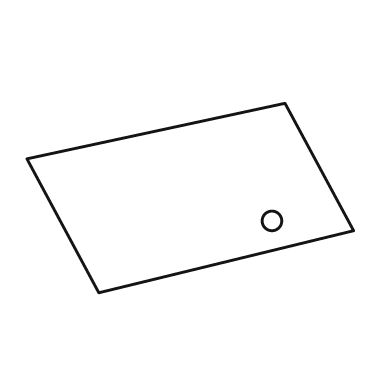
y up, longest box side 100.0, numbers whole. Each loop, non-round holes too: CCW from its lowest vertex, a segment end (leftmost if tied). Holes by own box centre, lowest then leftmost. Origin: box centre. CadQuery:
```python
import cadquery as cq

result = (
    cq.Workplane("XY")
    .moveTo(-28.0, -29.0)
    .lineTo(50.0, -10.0)
    .lineTo(29.0, 29.0)
    .lineTo(-50.0, 12.0)
    .close()
    .moveTo(25.0, -7.0)
    .circle(3.0)
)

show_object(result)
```